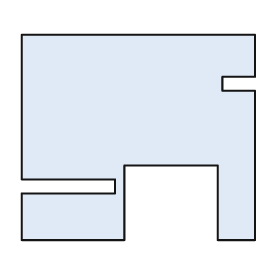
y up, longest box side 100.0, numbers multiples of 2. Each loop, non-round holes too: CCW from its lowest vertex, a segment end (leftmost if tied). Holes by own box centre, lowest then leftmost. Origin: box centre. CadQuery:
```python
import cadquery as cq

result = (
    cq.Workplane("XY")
    .moveTo(-50.0, -44.0)
    .lineTo(-6.0, -44.0)
    .lineTo(-6.0, -12.0)
    .lineTo(34.0, -12.0)
    .lineTo(34.0, -44.0)
    .lineTo(50.0, -44.0)
    .lineTo(50.0, 20.0)
    .lineTo(36.0, 20.0)
    .lineTo(36.0, 26.0)
    .lineTo(50.0, 26.0)
    .lineTo(50.0, 44.0)
    .lineTo(-50.0, 44.0)
    .lineTo(-50.0, -18.0)
    .lineTo(-10.0, -18.0)
    .lineTo(-10.0, -24.0)
    .lineTo(-50.0, -24.0)
    .close()
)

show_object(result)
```